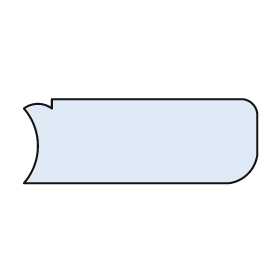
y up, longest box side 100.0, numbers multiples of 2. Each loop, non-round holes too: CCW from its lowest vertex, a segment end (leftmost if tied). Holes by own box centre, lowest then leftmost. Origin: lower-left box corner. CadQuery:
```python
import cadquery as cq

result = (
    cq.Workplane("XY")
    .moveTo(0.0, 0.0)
    .lineTo(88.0, 0.0)
    .threePointArc((96.0, 4.0), (100.0, 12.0))
    .lineTo(100.0, 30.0)
    .threePointArc((98.0, 34.0), (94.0, 36.0))
    .lineTo(12.0, 36.0)
    .lineTo(12.0, 32.0)
    .threePointArc((6.0, 34.0), (0.0, 32.0))
    .threePointArc((6.0, 16.0), (0.0, 0.0))
    .close()
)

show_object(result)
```